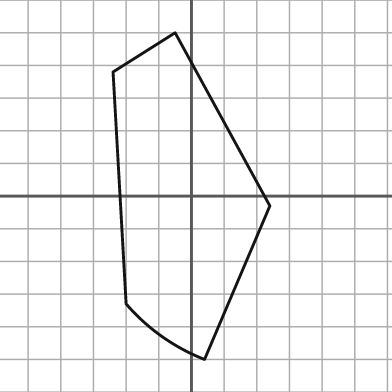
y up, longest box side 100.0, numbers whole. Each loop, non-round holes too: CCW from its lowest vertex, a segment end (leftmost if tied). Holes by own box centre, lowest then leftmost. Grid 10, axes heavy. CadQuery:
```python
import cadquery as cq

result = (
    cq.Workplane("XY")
    .moveTo(4.0, -50.0)
    .lineTo(24.0, -3.0)
    .lineTo(-5.0, 50.0)
    .lineTo(-24.0, 38.0)
    .lineTo(-20.0, -33.0)
    .threePointArc((-9.0, -43.0), (4.0, -50.0))
    .close()
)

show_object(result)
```